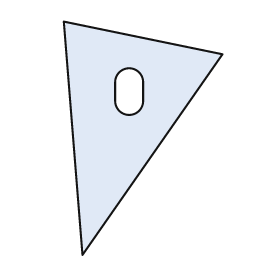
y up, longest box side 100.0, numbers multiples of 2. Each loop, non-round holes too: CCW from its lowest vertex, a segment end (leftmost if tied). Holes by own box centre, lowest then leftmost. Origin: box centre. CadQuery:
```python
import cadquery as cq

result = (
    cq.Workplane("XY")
    .moveTo(-26.0, -50.0)
    .lineTo(34.0, 36.0)
    .lineTo(-34.0, 50.0)
    .close()
    .moveTo(-12.0, 16.0)
    .threePointArc((-6.0, 10.0), (0.0, 16.0))
    .lineTo(0.0, 24.0)
    .threePointArc((-6.0, 30.0), (-12.0, 24.0))
    .close()
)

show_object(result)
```